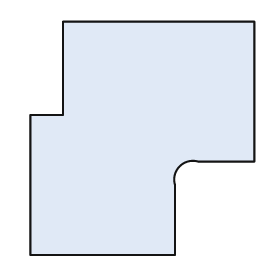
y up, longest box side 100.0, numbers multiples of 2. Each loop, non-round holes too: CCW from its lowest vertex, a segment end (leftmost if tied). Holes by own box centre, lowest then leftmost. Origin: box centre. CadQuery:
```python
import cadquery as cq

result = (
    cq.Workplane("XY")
    .moveTo(-48.0, -50.0)
    .lineTo(14.0, -50.0)
    .lineTo(14.0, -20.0)
    .threePointArc((16.0, -12.0), (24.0, -10.0))
    .lineTo(48.0, -10.0)
    .lineTo(48.0, 50.0)
    .lineTo(-34.0, 50.0)
    .lineTo(-34.0, 10.0)
    .lineTo(-48.0, 10.0)
    .close()
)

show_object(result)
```